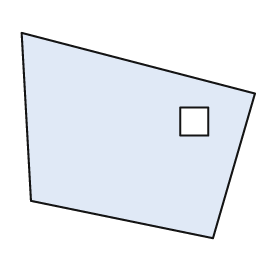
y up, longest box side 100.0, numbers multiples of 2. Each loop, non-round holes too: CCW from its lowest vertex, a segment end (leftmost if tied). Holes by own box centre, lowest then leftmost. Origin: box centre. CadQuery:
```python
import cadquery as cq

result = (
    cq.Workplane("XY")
    .moveTo(32.0, -44.0)
    .lineTo(50.0, 18.0)
    .lineTo(-50.0, 44.0)
    .lineTo(-46.0, -28.0)
    .close()
    .moveTo(18.0, 0.0)
    .lineTo(30.0, 0.0)
    .lineTo(30.0, 12.0)
    .lineTo(18.0, 12.0)
    .close()
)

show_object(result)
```